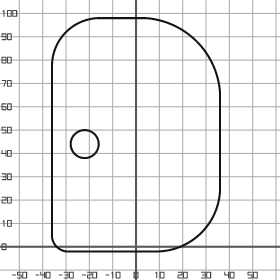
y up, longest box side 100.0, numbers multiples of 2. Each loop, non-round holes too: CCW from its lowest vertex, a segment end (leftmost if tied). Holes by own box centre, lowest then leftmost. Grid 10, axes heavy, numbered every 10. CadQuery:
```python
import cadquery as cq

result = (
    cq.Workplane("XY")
    .moveTo(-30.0, -2.0)
    .lineTo(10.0, -2.0)
    .threePointArc((28.0, 6.0), (36.0, 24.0))
    .lineTo(36.0, 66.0)
    .threePointArc((26.0, 88.0), (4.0, 98.0))
    .lineTo(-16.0, 98.0)
    .threePointArc((-30.0, 92.0), (-36.0, 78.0))
    .lineTo(-36.0, 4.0)
    .threePointArc((-34.0, 0.0), (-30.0, -2.0))
    .close()
    .moveTo(-22.0, 44.0)
    .circle(6.0)
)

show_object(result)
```